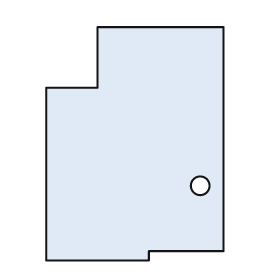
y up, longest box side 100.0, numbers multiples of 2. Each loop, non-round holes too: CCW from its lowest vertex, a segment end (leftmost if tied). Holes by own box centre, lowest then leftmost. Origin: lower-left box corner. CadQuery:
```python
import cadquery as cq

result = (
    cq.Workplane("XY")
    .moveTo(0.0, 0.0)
    .lineTo(44.0, 0.0)
    .lineTo(44.0, 4.0)
    .lineTo(76.0, 4.0)
    .lineTo(76.0, 100.0)
    .lineTo(22.0, 100.0)
    .lineTo(22.0, 74.0)
    .lineTo(0.0, 74.0)
    .close()
    .moveTo(66.0, 32.0)
    .circle(4.0)
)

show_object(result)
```